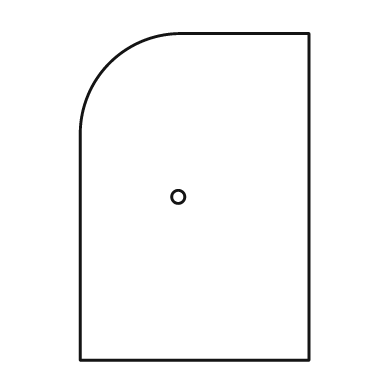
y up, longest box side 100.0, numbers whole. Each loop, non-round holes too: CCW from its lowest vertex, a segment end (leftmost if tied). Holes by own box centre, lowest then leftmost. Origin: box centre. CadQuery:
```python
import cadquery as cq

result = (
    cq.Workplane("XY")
    .moveTo(-35.0, -50.0)
    .lineTo(35.0, -50.0)
    .lineTo(35.0, 50.0)
    .lineTo(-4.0, 50.0)
    .threePointArc((-26.0, 41.0), (-35.0, 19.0))
    .close()
    .moveTo(-5.0, 0.0)
    .circle(2.0)
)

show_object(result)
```